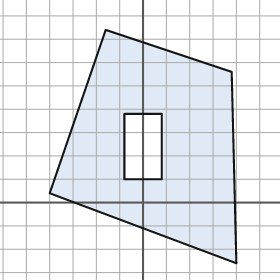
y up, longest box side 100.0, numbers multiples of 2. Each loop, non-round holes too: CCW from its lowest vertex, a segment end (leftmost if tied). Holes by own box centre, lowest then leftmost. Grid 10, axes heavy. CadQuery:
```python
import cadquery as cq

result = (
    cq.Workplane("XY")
    .moveTo(40.0, -26.0)
    .lineTo(38.0, 56.0)
    .lineTo(-16.0, 74.0)
    .lineTo(-40.0, 4.0)
    .close()
    .moveTo(-8.0, 10.0)
    .lineTo(8.0, 10.0)
    .lineTo(8.0, 38.0)
    .lineTo(-8.0, 38.0)
    .close()
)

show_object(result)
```